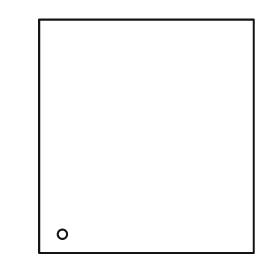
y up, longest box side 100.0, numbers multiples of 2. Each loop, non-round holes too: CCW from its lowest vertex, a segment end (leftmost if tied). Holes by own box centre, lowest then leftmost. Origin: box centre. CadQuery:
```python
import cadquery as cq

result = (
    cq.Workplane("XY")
    .moveTo(-46.0, -50.0)
    .lineTo(46.0, -50.0)
    .lineTo(46.0, 50.0)
    .lineTo(-46.0, 50.0)
    .close()
    .moveTo(-36.0, -42.0)
    .circle(2.0)
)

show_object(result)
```